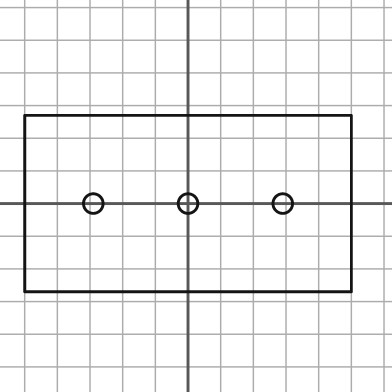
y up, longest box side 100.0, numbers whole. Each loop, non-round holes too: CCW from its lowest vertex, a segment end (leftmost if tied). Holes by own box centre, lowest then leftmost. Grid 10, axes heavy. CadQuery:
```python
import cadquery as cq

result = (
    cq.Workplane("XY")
    .moveTo(-50.0, -27.0)
    .lineTo(50.0, -27.0)
    .lineTo(50.0, 27.0)
    .lineTo(-50.0, 27.0)
    .close()
    .moveTo(-29.0, 0.0)
    .circle(3.0)
    .moveTo(0.0, 0.0)
    .circle(3.0)
    .moveTo(29.0, 0.0)
    .circle(3.0)
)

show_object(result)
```